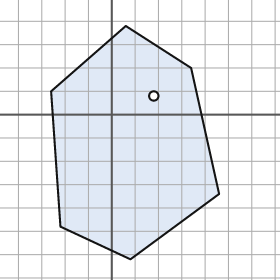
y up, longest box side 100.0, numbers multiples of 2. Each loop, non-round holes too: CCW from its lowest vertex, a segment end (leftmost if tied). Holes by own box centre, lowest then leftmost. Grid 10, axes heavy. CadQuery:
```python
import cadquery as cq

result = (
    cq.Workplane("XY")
    .moveTo(8.0, -62.0)
    .lineTo(46.0, -34.0)
    .lineTo(34.0, 20.0)
    .lineTo(6.0, 38.0)
    .lineTo(-26.0, 10.0)
    .lineTo(-22.0, -48.0)
    .close()
    .moveTo(18.0, 8.0)
    .circle(2.0)
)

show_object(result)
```